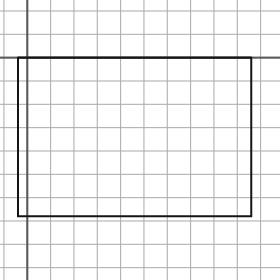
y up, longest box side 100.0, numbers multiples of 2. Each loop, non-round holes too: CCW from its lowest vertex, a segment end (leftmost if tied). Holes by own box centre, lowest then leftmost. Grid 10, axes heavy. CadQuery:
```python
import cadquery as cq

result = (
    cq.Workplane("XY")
    .moveTo(-4.0, -68.0)
    .lineTo(96.0, -68.0)
    .lineTo(96.0, 0.0)
    .lineTo(-4.0, 0.0)
    .close()
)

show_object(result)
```